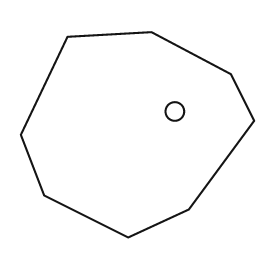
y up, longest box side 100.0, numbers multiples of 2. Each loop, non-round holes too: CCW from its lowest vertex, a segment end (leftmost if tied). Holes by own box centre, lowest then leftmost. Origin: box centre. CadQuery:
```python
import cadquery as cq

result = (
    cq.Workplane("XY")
    .moveTo(-4.0, -44.0)
    .lineTo(22.0, -32.0)
    .lineTo(50.0, 6.0)
    .lineTo(40.0, 26.0)
    .lineTo(6.0, 44.0)
    .lineTo(-30.0, 42.0)
    .lineTo(-50.0, 0.0)
    .lineTo(-40.0, -26.0)
    .close()
    .moveTo(16.0, 10.0)
    .circle(4.0)
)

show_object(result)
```